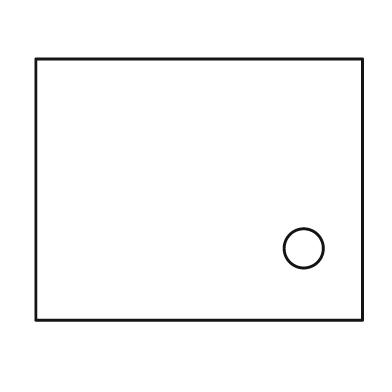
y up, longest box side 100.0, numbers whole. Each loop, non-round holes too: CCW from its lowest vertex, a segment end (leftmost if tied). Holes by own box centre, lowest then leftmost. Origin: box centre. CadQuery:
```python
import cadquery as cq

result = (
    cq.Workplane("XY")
    .moveTo(-50.0, -40.0)
    .lineTo(50.0, -40.0)
    .lineTo(50.0, 40.0)
    .lineTo(-50.0, 40.0)
    .close()
    .moveTo(32.0, -18.0)
    .circle(6.0)
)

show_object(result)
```